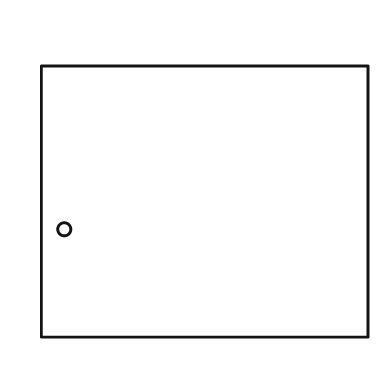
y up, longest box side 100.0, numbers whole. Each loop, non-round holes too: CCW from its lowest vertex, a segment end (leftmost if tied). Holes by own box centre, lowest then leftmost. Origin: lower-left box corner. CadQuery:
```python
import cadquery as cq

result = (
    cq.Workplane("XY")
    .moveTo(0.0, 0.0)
    .lineTo(100.0, 0.0)
    .lineTo(100.0, 83.0)
    .lineTo(0.0, 83.0)
    .close()
    .moveTo(7.0, 33.0)
    .circle(2.0)
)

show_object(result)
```